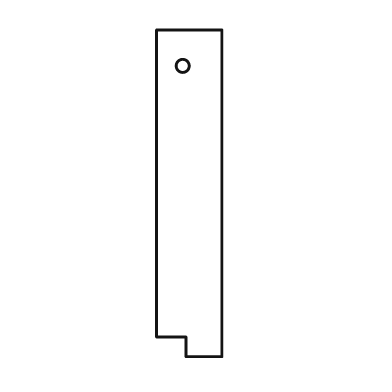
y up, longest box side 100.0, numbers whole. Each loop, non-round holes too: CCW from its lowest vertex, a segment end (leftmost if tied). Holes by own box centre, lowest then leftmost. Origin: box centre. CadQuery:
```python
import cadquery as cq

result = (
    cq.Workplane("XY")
    .moveTo(-1.0, -50.0)
    .lineTo(10.0, -50.0)
    .lineTo(10.0, 50.0)
    .lineTo(-10.0, 50.0)
    .lineTo(-10.0, -44.0)
    .lineTo(-1.0, -44.0)
    .close()
    .moveTo(-2.0, 39.0)
    .circle(2.0)
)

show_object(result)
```